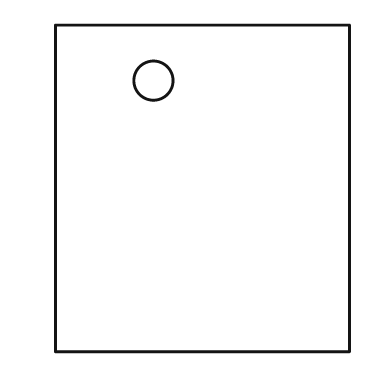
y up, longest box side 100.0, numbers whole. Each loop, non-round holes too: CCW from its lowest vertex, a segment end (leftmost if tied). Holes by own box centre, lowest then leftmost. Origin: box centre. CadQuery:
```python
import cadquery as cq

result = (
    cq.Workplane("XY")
    .moveTo(-45.0, -50.0)
    .lineTo(45.0, -50.0)
    .lineTo(45.0, 50.0)
    .lineTo(-45.0, 50.0)
    .close()
    .moveTo(-15.0, 33.0)
    .circle(6.0)
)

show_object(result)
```